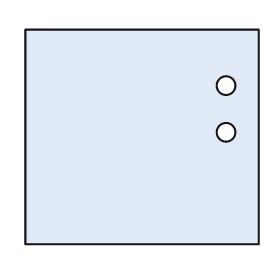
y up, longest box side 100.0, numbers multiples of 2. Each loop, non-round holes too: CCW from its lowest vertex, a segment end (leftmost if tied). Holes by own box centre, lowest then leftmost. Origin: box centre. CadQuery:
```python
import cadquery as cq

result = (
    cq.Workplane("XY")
    .moveTo(-50.0, -46.0)
    .lineTo(50.0, -46.0)
    .lineTo(50.0, 46.0)
    .lineTo(-50.0, 46.0)
    .close()
    .moveTo(36.0, 2.0)
    .circle(4.0)
    .moveTo(36.0, 22.0)
    .circle(4.0)
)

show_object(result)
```